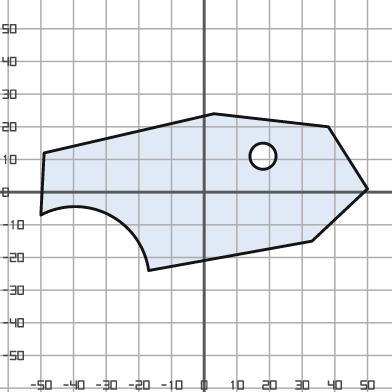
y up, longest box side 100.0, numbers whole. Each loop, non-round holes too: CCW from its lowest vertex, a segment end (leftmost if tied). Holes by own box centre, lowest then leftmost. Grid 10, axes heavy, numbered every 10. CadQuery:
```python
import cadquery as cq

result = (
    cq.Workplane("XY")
    .moveTo(-17.0, -24.0)
    .lineTo(33.0, -15.0)
    .lineTo(50.0, 1.0)
    .lineTo(38.0, 20.0)
    .lineTo(3.0, 24.0)
    .lineTo(-49.0, 12.0)
    .lineTo(-50.0, -7.0)
    .threePointArc((-29.0, -7.0), (-17.0, -24.0))
    .close()
    .moveTo(18.0, 11.0)
    .circle(4.0)
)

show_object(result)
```